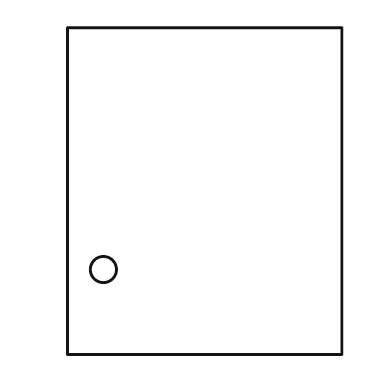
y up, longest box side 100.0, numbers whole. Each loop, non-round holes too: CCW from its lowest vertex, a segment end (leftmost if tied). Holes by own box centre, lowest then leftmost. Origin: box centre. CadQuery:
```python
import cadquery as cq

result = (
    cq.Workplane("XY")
    .moveTo(-42.0, -50.0)
    .lineTo(42.0, -50.0)
    .lineTo(42.0, 50.0)
    .lineTo(-42.0, 50.0)
    .close()
    .moveTo(-31.0, -24.0)
    .circle(4.0)
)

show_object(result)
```